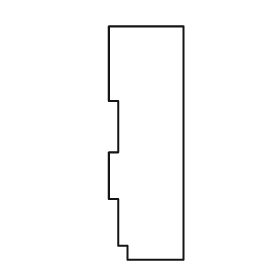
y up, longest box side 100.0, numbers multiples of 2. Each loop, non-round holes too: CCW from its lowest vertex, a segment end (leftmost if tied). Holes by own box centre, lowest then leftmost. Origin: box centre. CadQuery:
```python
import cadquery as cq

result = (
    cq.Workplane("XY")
    .moveTo(-8.0, -50.0)
    .lineTo(16.0, -50.0)
    .lineTo(16.0, 50.0)
    .lineTo(-16.0, 50.0)
    .lineTo(-16.0, 18.0)
    .lineTo(-12.0, 18.0)
    .lineTo(-12.0, -4.0)
    .lineTo(-16.0, -4.0)
    .lineTo(-16.0, -24.0)
    .lineTo(-12.0, -24.0)
    .lineTo(-12.0, -44.0)
    .lineTo(-8.0, -44.0)
    .close()
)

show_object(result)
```